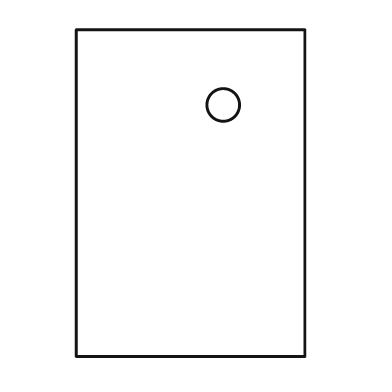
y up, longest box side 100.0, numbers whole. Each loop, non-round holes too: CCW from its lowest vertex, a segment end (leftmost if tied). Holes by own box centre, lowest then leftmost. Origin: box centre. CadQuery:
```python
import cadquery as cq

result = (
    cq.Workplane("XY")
    .moveTo(-35.0, -50.0)
    .lineTo(35.0, -50.0)
    .lineTo(35.0, 50.0)
    .lineTo(-35.0, 50.0)
    .close()
    .moveTo(10.0, 27.0)
    .circle(5.0)
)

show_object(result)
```